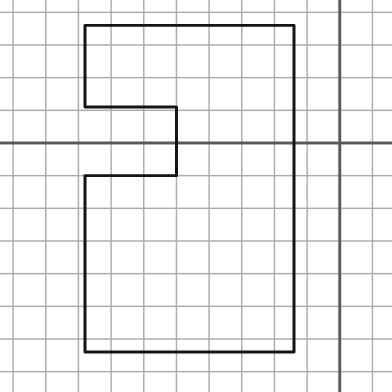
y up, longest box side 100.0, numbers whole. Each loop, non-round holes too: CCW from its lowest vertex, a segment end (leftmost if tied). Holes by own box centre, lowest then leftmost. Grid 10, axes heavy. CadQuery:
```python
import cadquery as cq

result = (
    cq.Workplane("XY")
    .moveTo(-78.0, -64.0)
    .lineTo(-14.0, -64.0)
    .lineTo(-14.0, 36.0)
    .lineTo(-78.0, 36.0)
    .lineTo(-78.0, 11.0)
    .lineTo(-50.0, 11.0)
    .lineTo(-50.0, -10.0)
    .lineTo(-78.0, -10.0)
    .close()
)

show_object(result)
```